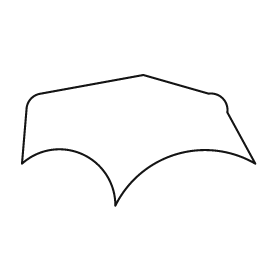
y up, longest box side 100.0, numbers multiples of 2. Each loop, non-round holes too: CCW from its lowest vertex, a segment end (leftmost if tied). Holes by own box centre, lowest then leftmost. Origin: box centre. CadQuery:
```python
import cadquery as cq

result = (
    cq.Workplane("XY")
    .moveTo(-10.0, -28.0)
    .threePointArc((16.0, -6.0), (50.0, -10.0))
    .lineTo(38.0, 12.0)
    .threePointArc((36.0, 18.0), (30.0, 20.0))
    .lineTo(2.0, 28.0)
    .lineTo(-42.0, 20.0)
    .threePointArc((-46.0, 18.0), (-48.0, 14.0))
    .lineTo(-50.0, -10.0)
    .threePointArc((-24.0, -6.0), (-10.0, -28.0))
    .close()
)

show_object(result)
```